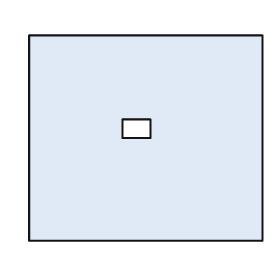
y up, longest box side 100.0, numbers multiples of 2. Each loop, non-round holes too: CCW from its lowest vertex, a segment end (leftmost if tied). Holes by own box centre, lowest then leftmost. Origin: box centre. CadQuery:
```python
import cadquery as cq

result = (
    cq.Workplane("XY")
    .moveTo(-50.0, -44.0)
    .lineTo(50.0, -44.0)
    .lineTo(50.0, 44.0)
    .lineTo(-50.0, 44.0)
    .close()
    .moveTo(-10.0, 0.0)
    .lineTo(2.0, 0.0)
    .lineTo(2.0, 8.0)
    .lineTo(-10.0, 8.0)
    .close()
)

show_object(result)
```